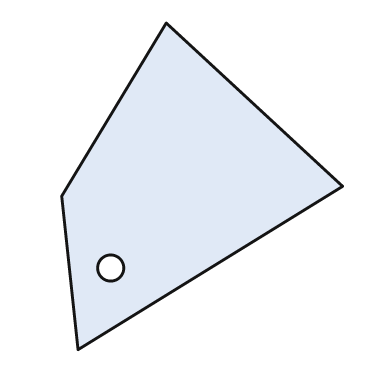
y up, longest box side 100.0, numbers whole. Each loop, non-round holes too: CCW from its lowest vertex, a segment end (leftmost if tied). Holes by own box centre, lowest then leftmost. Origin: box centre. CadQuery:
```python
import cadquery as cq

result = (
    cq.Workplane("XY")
    .moveTo(-38.0, -50.0)
    .lineTo(43.0, 0.0)
    .lineTo(-11.0, 50.0)
    .lineTo(-43.0, -3.0)
    .close()
    .moveTo(-28.0, -25.0)
    .circle(4.0)
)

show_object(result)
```